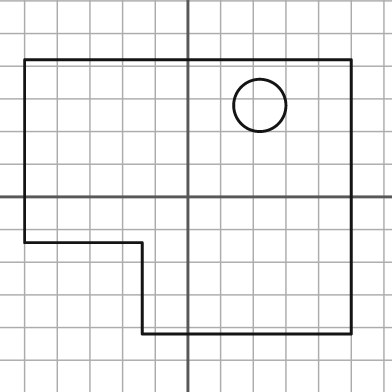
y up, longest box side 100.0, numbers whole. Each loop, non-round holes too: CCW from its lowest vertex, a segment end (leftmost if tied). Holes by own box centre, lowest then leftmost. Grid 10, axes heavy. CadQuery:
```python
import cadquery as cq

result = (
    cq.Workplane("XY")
    .moveTo(-14.0, -42.0)
    .lineTo(50.0, -42.0)
    .lineTo(50.0, 42.0)
    .lineTo(-50.0, 42.0)
    .lineTo(-50.0, -14.0)
    .lineTo(-14.0, -14.0)
    .close()
    .moveTo(22.0, 28.0)
    .circle(8.0)
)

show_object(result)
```